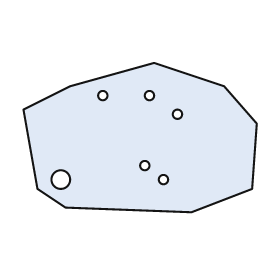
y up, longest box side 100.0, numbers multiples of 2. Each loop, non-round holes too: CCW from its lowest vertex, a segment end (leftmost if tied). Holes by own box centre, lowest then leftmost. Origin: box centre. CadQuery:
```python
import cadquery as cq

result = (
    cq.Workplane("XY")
    .moveTo(22.0, -32.0)
    .lineTo(48.0, -22.0)
    .lineTo(50.0, 6.0)
    .lineTo(36.0, 22.0)
    .lineTo(6.0, 32.0)
    .lineTo(-30.0, 22.0)
    .lineTo(-50.0, 12.0)
    .lineTo(-44.0, -22.0)
    .lineTo(-32.0, -30.0)
    .close()
    .moveTo(-34.0, -18.0)
    .circle(4.0)
    .moveTo(10.0, -18.0)
    .circle(2.0)
    .moveTo(2.0, -12.0)
    .circle(2.0)
    .moveTo(16.0, 10.0)
    .circle(2.0)
    .moveTo(-16.0, 18.0)
    .circle(2.0)
    .moveTo(4.0, 18.0)
    .circle(2.0)
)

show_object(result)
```